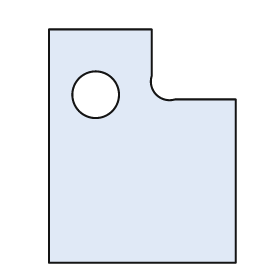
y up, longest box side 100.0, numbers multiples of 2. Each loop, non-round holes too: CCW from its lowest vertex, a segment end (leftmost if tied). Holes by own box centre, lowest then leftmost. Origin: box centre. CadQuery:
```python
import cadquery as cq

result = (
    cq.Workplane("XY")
    .moveTo(-40.0, -50.0)
    .lineTo(40.0, -50.0)
    .lineTo(40.0, 20.0)
    .lineTo(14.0, 20.0)
    .threePointArc((6.0, 22.0), (4.0, 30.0))
    .lineTo(4.0, 50.0)
    .lineTo(-40.0, 50.0)
    .close()
    .moveTo(-20.0, 22.0)
    .circle(10.0)
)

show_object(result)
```